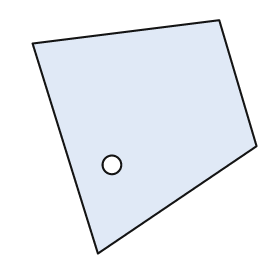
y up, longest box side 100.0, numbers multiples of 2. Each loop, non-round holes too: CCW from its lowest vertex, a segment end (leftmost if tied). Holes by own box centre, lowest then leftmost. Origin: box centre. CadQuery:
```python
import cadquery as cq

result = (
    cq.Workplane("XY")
    .moveTo(-20.0, -50.0)
    .lineTo(48.0, -4.0)
    .lineTo(32.0, 50.0)
    .lineTo(-48.0, 40.0)
    .close()
    .moveTo(-14.0, -12.0)
    .circle(4.0)
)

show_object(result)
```